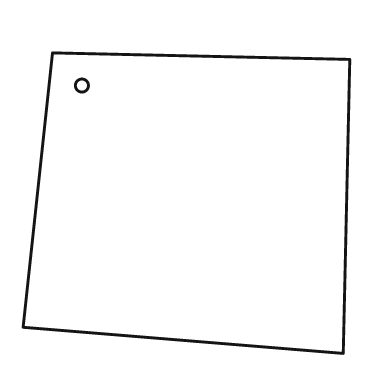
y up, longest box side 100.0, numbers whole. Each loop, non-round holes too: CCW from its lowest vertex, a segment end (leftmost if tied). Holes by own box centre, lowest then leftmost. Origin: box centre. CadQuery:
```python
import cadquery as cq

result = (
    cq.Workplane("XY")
    .moveTo(48.0, -46.0)
    .lineTo(50.0, 44.0)
    .lineTo(-41.0, 46.0)
    .lineTo(-50.0, -38.0)
    .close()
    .moveTo(-32.0, 36.0)
    .circle(2.0)
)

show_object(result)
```